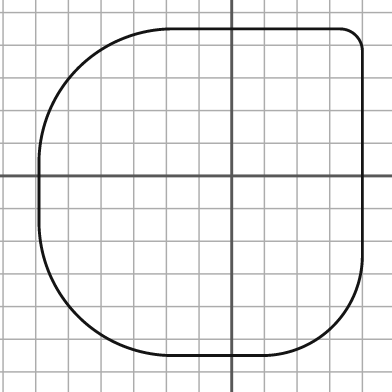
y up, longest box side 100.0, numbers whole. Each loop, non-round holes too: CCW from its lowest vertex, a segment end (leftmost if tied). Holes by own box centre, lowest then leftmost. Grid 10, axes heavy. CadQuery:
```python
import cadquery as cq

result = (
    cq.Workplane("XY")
    .moveTo(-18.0, -55.0)
    .lineTo(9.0, -55.0)
    .threePointArc((31.0, -46.0), (40.0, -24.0))
    .lineTo(40.0, 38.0)
    .threePointArc((38.0, 43.0), (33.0, 45.0))
    .lineTo(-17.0, 45.0)
    .threePointArc((-47.0, 33.0), (-59.0, 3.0))
    .lineTo(-59.0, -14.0)
    .threePointArc((-47.0, -43.0), (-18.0, -55.0))
    .close()
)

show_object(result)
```